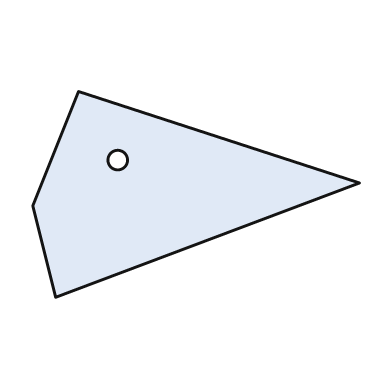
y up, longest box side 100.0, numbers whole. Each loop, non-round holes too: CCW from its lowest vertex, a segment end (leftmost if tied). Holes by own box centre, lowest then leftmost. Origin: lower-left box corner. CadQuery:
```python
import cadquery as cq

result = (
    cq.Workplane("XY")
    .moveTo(7.0, 0.0)
    .lineTo(100.0, 35.0)
    .lineTo(14.0, 63.0)
    .lineTo(0.0, 28.0)
    .close()
    .moveTo(26.0, 42.0)
    .circle(3.0)
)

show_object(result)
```